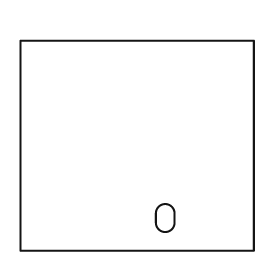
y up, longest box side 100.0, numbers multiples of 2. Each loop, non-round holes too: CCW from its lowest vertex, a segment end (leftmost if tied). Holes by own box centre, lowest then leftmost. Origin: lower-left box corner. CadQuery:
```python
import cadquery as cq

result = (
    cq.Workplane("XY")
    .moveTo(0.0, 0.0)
    .lineTo(100.0, 0.0)
    .lineTo(100.0, 90.0)
    .lineTo(0.0, 90.0)
    .close()
    .moveTo(58.0, 12.0)
    .threePointArc((62.0, 8.0), (66.0, 12.0))
    .lineTo(66.0, 16.0)
    .threePointArc((62.0, 20.0), (58.0, 16.0))
    .close()
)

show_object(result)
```